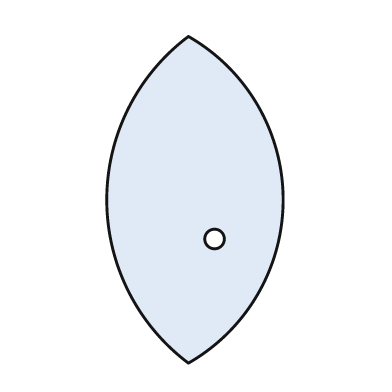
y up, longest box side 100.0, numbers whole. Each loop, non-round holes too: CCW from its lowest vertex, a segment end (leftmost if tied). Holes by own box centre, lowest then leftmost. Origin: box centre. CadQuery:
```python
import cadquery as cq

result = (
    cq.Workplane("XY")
    .moveTo(-2.0, -50.0)
    .threePointArc((27.0, 0.0), (-2.0, 50.0))
    .threePointArc((-27.0, 0.0), (-2.0, -50.0))
    .close()
    .moveTo(6.0, -12.0)
    .circle(3.0)
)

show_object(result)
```